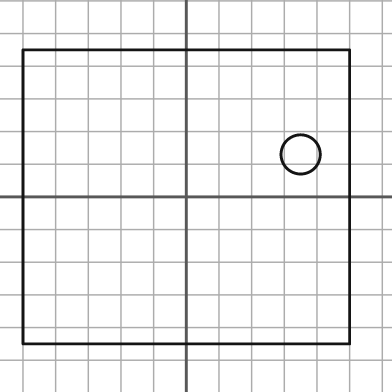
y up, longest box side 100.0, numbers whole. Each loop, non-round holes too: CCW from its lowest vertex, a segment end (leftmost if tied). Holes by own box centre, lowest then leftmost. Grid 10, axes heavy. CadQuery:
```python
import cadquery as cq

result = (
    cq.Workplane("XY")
    .moveTo(-50.0, -45.0)
    .lineTo(50.0, -45.0)
    .lineTo(50.0, 45.0)
    .lineTo(-50.0, 45.0)
    .close()
    .moveTo(35.0, 13.0)
    .circle(6.0)
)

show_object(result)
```